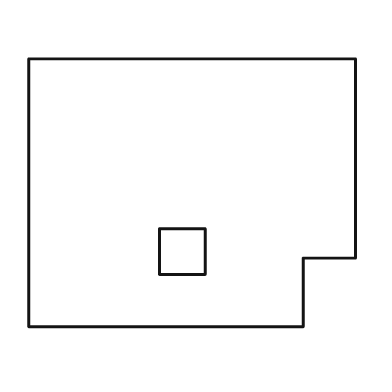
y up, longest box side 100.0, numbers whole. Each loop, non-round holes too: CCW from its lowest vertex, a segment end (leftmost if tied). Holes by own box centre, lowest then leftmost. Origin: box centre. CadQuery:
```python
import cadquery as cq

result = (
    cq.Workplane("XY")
    .moveTo(-50.0, -41.0)
    .lineTo(34.0, -41.0)
    .lineTo(34.0, -20.0)
    .lineTo(50.0, -20.0)
    .lineTo(50.0, 41.0)
    .lineTo(-50.0, 41.0)
    .close()
    .moveTo(-10.0, -25.0)
    .lineTo(4.0, -25.0)
    .lineTo(4.0, -11.0)
    .lineTo(-10.0, -11.0)
    .close()
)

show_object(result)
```